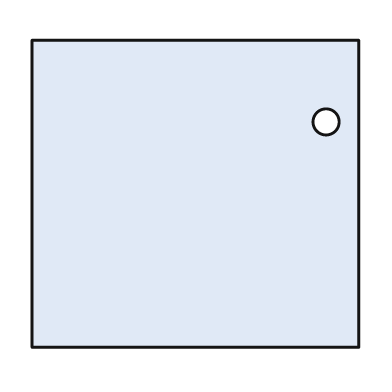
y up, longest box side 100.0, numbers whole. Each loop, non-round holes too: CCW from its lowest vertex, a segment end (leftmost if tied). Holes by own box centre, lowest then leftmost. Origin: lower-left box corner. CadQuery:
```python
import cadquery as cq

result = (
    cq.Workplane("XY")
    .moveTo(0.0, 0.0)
    .lineTo(100.0, 0.0)
    .lineTo(100.0, 94.0)
    .lineTo(0.0, 94.0)
    .close()
    .moveTo(90.0, 69.0)
    .circle(4.0)
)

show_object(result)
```